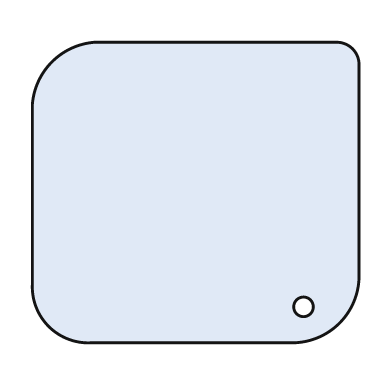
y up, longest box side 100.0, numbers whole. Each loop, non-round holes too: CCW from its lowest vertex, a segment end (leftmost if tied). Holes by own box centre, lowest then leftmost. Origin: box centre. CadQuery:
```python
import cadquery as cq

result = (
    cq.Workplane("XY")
    .moveTo(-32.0, -46.0)
    .lineTo(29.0, -46.0)
    .threePointArc((44.0, -40.0), (50.0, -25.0))
    .lineTo(50.0, 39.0)
    .threePointArc((48.0, 44.0), (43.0, 46.0))
    .lineTo(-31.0, 46.0)
    .threePointArc((-44.0, 40.0), (-50.0, 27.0))
    .lineTo(-50.0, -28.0)
    .threePointArc((-45.0, -41.0), (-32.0, -46.0))
    .close()
    .moveTo(33.0, -35.0)
    .circle(3.0)
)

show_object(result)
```